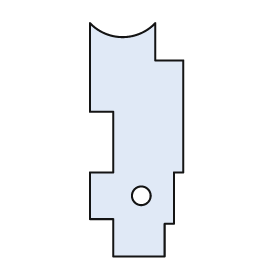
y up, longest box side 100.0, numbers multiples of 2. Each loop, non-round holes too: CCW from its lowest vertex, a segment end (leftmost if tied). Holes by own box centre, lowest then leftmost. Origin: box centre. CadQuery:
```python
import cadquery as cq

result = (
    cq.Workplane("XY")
    .moveTo(-10.0, -50.0)
    .lineTo(12.0, -50.0)
    .lineTo(12.0, -36.0)
    .lineTo(16.0, -36.0)
    .lineTo(16.0, -14.0)
    .lineTo(20.0, -14.0)
    .lineTo(20.0, 34.0)
    .lineTo(8.0, 34.0)
    .lineTo(8.0, 50.0)
    .threePointArc((-6.0, 44.0), (-20.0, 50.0))
    .lineTo(-20.0, 12.0)
    .lineTo(-10.0, 12.0)
    .lineTo(-10.0, -14.0)
    .lineTo(-20.0, -14.0)
    .lineTo(-20.0, -34.0)
    .lineTo(-10.0, -34.0)
    .close()
    .moveTo(2.0, -24.0)
    .circle(4.0)
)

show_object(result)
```